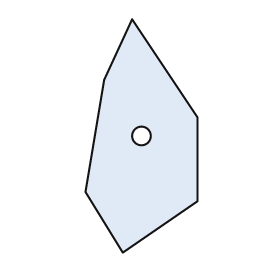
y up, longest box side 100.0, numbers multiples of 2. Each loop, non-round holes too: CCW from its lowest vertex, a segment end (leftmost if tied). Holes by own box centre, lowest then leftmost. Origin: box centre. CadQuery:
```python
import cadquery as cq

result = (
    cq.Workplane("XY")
    .moveTo(-8.0, -50.0)
    .lineTo(24.0, -28.0)
    .lineTo(24.0, 8.0)
    .lineTo(-4.0, 50.0)
    .lineTo(-16.0, 24.0)
    .lineTo(-24.0, -24.0)
    .close()
    .moveTo(0.0, 0.0)
    .circle(4.0)
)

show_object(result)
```